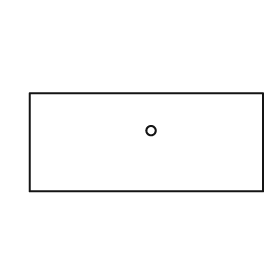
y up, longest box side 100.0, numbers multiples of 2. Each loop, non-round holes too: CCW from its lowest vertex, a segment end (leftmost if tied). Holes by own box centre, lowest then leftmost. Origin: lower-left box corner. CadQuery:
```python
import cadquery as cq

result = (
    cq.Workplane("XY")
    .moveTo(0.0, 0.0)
    .lineTo(100.0, 0.0)
    .lineTo(100.0, 42.0)
    .lineTo(0.0, 42.0)
    .close()
    .moveTo(52.0, 26.0)
    .circle(2.0)
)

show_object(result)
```